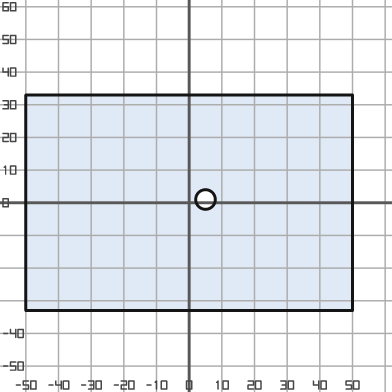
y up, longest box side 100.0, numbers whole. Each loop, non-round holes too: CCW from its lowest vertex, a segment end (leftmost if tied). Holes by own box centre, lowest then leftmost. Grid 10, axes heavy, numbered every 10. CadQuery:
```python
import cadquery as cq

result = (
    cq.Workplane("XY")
    .moveTo(-50.0, -33.0)
    .lineTo(50.0, -33.0)
    .lineTo(50.0, 33.0)
    .lineTo(-50.0, 33.0)
    .close()
    .moveTo(5.0, 1.0)
    .circle(3.0)
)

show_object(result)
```